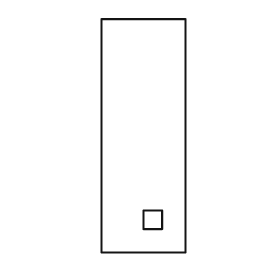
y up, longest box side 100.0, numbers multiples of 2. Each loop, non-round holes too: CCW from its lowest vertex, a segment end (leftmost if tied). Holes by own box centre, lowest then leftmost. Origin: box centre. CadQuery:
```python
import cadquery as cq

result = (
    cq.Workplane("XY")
    .moveTo(-18.0, -50.0)
    .lineTo(18.0, -50.0)
    .lineTo(18.0, 50.0)
    .lineTo(-18.0, 50.0)
    .close()
    .moveTo(0.0, -40.0)
    .lineTo(8.0, -40.0)
    .lineTo(8.0, -32.0)
    .lineTo(0.0, -32.0)
    .close()
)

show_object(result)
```